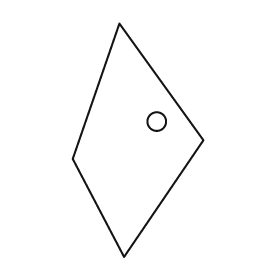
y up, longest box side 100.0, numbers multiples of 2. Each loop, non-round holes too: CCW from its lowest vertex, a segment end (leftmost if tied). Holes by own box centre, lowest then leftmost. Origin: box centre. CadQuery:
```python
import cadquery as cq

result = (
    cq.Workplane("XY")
    .moveTo(-6.0, -50.0)
    .lineTo(28.0, 0.0)
    .lineTo(-8.0, 50.0)
    .lineTo(-28.0, -8.0)
    .close()
    .moveTo(8.0, 8.0)
    .circle(4.0)
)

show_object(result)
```